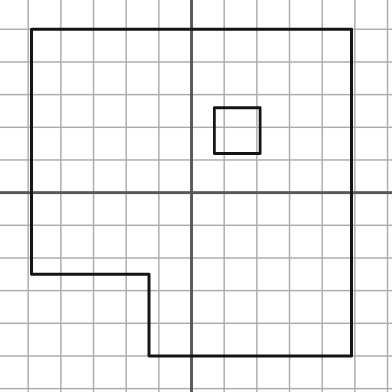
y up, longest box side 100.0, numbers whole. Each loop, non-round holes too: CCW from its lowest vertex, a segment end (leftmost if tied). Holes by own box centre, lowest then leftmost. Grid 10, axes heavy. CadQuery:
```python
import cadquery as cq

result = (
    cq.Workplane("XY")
    .moveTo(-13.0, -50.0)
    .lineTo(49.0, -50.0)
    .lineTo(49.0, 50.0)
    .lineTo(-49.0, 50.0)
    .lineTo(-49.0, -25.0)
    .lineTo(-13.0, -25.0)
    .close()
    .moveTo(7.0, 12.0)
    .lineTo(21.0, 12.0)
    .lineTo(21.0, 26.0)
    .lineTo(7.0, 26.0)
    .close()
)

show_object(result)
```